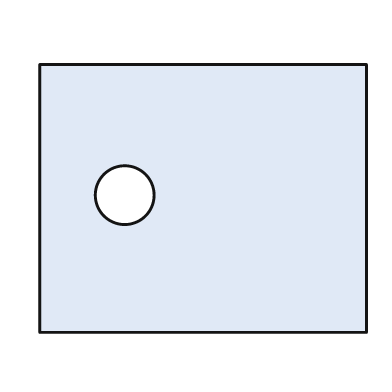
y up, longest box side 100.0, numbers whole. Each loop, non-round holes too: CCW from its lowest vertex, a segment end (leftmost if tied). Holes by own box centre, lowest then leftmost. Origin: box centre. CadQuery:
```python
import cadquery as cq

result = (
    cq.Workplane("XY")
    .moveTo(-50.0, -41.0)
    .lineTo(50.0, -41.0)
    .lineTo(50.0, 41.0)
    .lineTo(-50.0, 41.0)
    .close()
    .moveTo(-24.0, 1.0)
    .circle(9.0)
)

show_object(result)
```